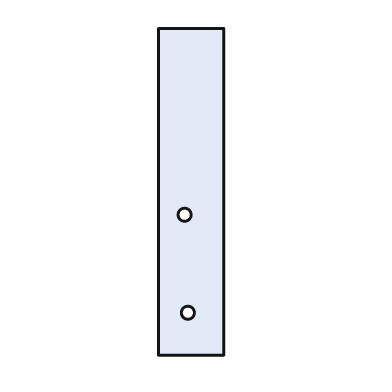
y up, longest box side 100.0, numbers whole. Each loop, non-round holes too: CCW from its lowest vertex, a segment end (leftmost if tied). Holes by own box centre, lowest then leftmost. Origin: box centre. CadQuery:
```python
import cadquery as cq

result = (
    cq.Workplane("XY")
    .moveTo(-10.0, -50.0)
    .lineTo(10.0, -50.0)
    .lineTo(10.0, 50.0)
    .lineTo(-10.0, 50.0)
    .close()
    .moveTo(-1.0, -37.0)
    .circle(2.0)
    .moveTo(-2.0, -7.0)
    .circle(2.0)
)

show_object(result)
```